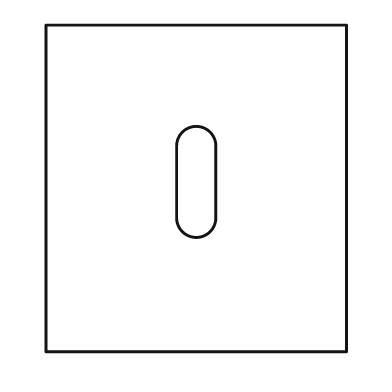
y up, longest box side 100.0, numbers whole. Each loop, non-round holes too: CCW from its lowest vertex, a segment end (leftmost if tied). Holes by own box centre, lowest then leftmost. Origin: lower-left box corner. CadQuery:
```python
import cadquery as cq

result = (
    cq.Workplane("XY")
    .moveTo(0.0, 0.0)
    .lineTo(92.0, 0.0)
    .lineTo(92.0, 100.0)
    .lineTo(0.0, 100.0)
    .close()
    .moveTo(40.0, 41.0)
    .threePointArc((46.0, 35.0), (52.0, 41.0))
    .lineTo(52.0, 63.0)
    .threePointArc((46.0, 69.0), (40.0, 63.0))
    .close()
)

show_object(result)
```